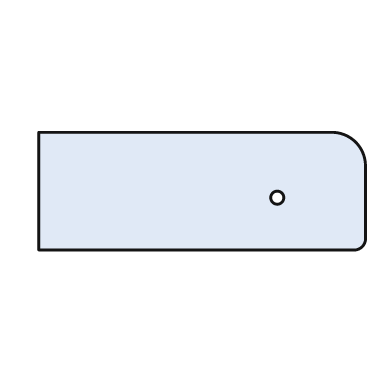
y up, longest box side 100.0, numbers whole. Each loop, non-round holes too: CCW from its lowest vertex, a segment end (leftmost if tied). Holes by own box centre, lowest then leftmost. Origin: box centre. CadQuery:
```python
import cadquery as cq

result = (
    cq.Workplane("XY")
    .moveTo(-50.0, -18.0)
    .lineTo(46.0, -18.0)
    .threePointArc((49.0, -17.0), (50.0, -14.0))
    .lineTo(50.0, 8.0)
    .threePointArc((47.0, 15.0), (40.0, 18.0))
    .lineTo(-50.0, 18.0)
    .close()
    .moveTo(23.0, -2.0)
    .circle(2.0)
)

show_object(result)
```